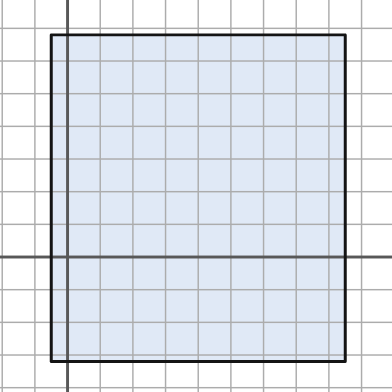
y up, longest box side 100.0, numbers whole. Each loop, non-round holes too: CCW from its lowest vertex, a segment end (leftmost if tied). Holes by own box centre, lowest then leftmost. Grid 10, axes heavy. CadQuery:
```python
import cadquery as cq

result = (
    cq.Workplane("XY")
    .moveTo(-5.0, -32.0)
    .lineTo(85.0, -32.0)
    .lineTo(85.0, 68.0)
    .lineTo(-5.0, 68.0)
    .close()
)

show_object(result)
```